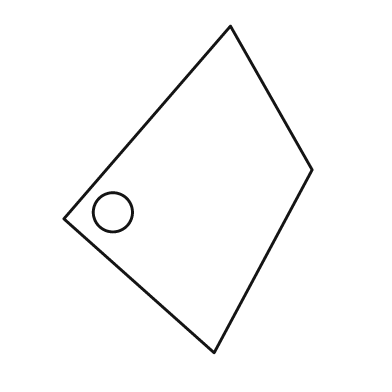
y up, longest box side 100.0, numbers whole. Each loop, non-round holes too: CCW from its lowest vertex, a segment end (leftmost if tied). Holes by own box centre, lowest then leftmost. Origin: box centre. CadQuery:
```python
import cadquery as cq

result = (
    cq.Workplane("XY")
    .moveTo(8.0, -50.0)
    .lineTo(38.0, 6.0)
    .lineTo(13.0, 50.0)
    .lineTo(-38.0, -9.0)
    .close()
    .moveTo(-23.0, -7.0)
    .circle(6.0)
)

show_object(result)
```